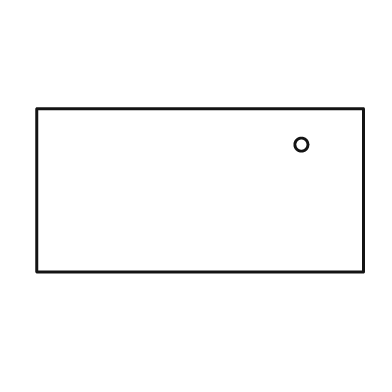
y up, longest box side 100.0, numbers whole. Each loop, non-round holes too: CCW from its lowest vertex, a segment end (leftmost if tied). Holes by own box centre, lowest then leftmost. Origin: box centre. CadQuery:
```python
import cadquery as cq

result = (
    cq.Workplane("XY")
    .moveTo(-50.0, -25.0)
    .lineTo(50.0, -25.0)
    .lineTo(50.0, 25.0)
    .lineTo(-50.0, 25.0)
    .close()
    .moveTo(31.0, 14.0)
    .circle(2.0)
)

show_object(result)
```